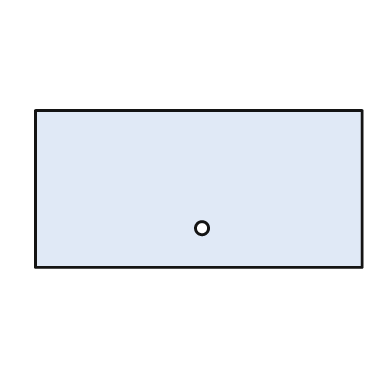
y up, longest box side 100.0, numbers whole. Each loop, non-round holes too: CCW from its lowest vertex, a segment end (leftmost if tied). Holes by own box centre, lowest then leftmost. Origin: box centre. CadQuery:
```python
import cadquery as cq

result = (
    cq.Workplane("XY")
    .moveTo(-50.0, -24.0)
    .lineTo(50.0, -24.0)
    .lineTo(50.0, 24.0)
    .lineTo(-50.0, 24.0)
    .close()
    .moveTo(1.0, -12.0)
    .circle(2.0)
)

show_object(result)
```